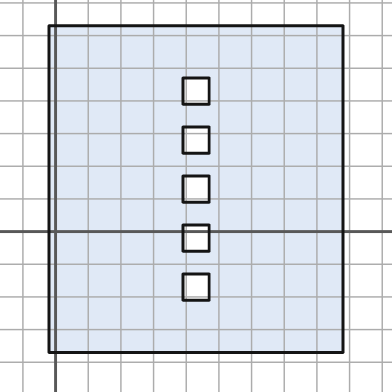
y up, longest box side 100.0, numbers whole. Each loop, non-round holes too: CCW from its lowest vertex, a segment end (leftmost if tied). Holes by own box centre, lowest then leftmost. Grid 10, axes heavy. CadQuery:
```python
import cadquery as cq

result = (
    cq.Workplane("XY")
    .moveTo(-2.0, -37.0)
    .lineTo(88.0, -37.0)
    .lineTo(88.0, 63.0)
    .lineTo(-2.0, 63.0)
    .close()
    .moveTo(39.0, -21.0)
    .lineTo(47.0, -21.0)
    .lineTo(47.0, -13.0)
    .lineTo(39.0, -13.0)
    .close()
    .moveTo(39.0, -6.0)
    .lineTo(47.0, -6.0)
    .lineTo(47.0, 2.0)
    .lineTo(39.0, 2.0)
    .close()
    .moveTo(39.0, 9.0)
    .lineTo(47.0, 9.0)
    .lineTo(47.0, 17.0)
    .lineTo(39.0, 17.0)
    .close()
    .moveTo(39.0, 24.0)
    .lineTo(47.0, 24.0)
    .lineTo(47.0, 32.0)
    .lineTo(39.0, 32.0)
    .close()
    .moveTo(39.0, 39.0)
    .lineTo(47.0, 39.0)
    .lineTo(47.0, 47.0)
    .lineTo(39.0, 47.0)
    .close()
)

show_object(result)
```